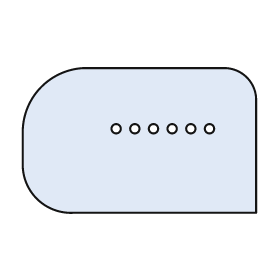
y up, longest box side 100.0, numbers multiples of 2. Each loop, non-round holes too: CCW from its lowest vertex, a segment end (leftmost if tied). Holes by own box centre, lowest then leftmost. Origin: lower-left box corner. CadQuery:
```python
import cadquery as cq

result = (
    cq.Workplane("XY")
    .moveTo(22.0, 0.0)
    .lineTo(100.0, 0.0)
    .lineTo(100.0, 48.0)
    .threePointArc((96.0, 58.0), (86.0, 62.0))
    .lineTo(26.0, 62.0)
    .threePointArc((8.0, 54.0), (0.0, 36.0))
    .lineTo(0.0, 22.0)
    .threePointArc((6.0, 6.0), (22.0, 0.0))
    .close()
    .moveTo(40.0, 36.0)
    .circle(2.0)
    .moveTo(48.0, 36.0)
    .circle(2.0)
    .moveTo(56.0, 36.0)
    .circle(2.0)
    .moveTo(64.0, 36.0)
    .circle(2.0)
    .moveTo(72.0, 36.0)
    .circle(2.0)
    .moveTo(80.0, 36.0)
    .circle(2.0)
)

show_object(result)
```